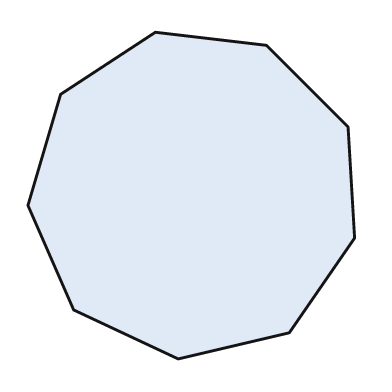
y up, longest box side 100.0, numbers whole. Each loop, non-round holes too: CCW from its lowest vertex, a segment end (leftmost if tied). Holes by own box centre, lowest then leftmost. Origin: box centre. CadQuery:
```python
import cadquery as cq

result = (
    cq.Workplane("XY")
    .moveTo(-4.0, -50.0)
    .lineTo(30.0, -42.0)
    .lineTo(50.0, -13.0)
    .lineTo(48.0, 21.0)
    .lineTo(23.0, 46.0)
    .lineTo(-11.0, 50.0)
    .lineTo(-40.0, 31.0)
    .lineTo(-50.0, -3.0)
    .lineTo(-36.0, -35.0)
    .close()
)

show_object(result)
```